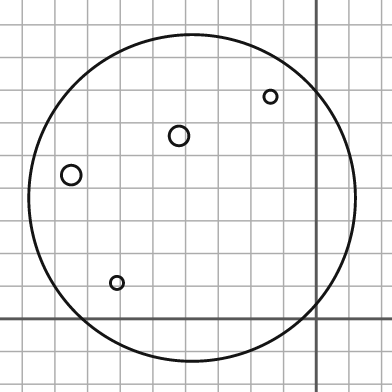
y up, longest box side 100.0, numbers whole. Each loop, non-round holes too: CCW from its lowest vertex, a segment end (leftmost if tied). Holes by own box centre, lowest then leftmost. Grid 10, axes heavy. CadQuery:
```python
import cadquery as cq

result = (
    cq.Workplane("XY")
    .moveTo(-38.0, 37.0)
    .circle(50.0)
    .moveTo(-61.0, 11.0)
    .circle(2.0)
    .moveTo(-75.0, 44.0)
    .circle(3.0)
    .moveTo(-42.0, 56.0)
    .circle(3.0)
    .moveTo(-14.0, 68.0)
    .circle(2.0)
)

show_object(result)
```